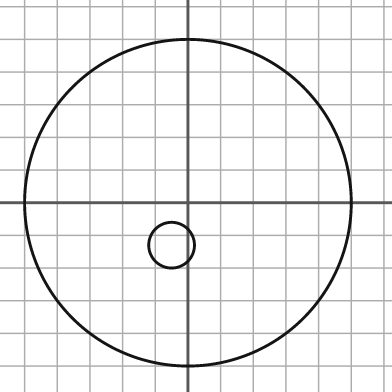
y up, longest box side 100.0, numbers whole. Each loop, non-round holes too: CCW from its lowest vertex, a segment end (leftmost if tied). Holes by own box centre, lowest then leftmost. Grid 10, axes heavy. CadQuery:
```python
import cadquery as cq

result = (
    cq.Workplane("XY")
    .moveTo(0.0, 0.0)
    .circle(50.0)
    .moveTo(-5.0, -13.0)
    .circle(7.0)
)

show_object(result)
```